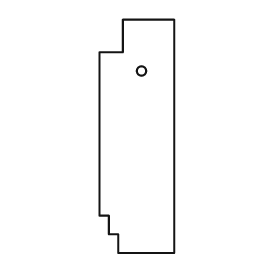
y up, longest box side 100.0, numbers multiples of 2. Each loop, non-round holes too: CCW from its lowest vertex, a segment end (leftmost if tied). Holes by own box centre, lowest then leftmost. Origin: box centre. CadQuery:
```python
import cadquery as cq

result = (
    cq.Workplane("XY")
    .moveTo(-8.0, -50.0)
    .lineTo(16.0, -50.0)
    .lineTo(16.0, 50.0)
    .lineTo(-6.0, 50.0)
    .lineTo(-6.0, 36.0)
    .lineTo(-16.0, 36.0)
    .lineTo(-16.0, -34.0)
    .lineTo(-12.0, -34.0)
    .lineTo(-12.0, -42.0)
    .lineTo(-8.0, -42.0)
    .close()
    .moveTo(2.0, 28.0)
    .circle(2.0)
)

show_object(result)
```